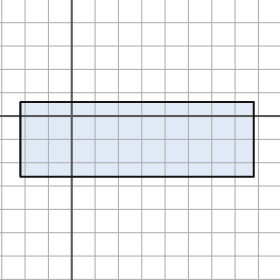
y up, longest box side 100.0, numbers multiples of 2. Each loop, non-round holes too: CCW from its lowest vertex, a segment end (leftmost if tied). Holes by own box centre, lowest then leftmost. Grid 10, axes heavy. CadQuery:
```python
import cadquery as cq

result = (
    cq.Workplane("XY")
    .moveTo(-22.0, -26.0)
    .lineTo(78.0, -26.0)
    .lineTo(78.0, 6.0)
    .lineTo(-22.0, 6.0)
    .close()
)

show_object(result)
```